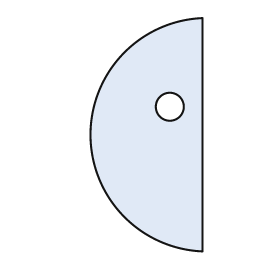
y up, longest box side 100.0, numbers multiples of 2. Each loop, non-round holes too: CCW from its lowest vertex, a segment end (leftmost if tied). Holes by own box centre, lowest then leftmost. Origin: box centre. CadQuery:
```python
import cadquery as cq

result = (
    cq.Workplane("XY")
    .moveTo(24.0, -50.0)
    .lineTo(24.0, 50.0)
    .threePointArc((-24.0, 0.0), (24.0, -50.0))
    .close()
    .moveTo(10.0, 12.0)
    .circle(6.0)
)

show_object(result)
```